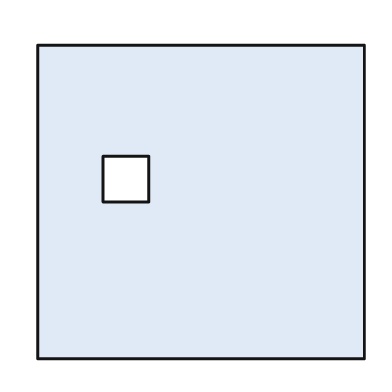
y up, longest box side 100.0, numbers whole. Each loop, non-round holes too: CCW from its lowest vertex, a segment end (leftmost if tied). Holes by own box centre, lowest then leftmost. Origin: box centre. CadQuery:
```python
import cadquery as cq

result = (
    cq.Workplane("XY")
    .moveTo(-50.0, -48.0)
    .lineTo(50.0, -48.0)
    .lineTo(50.0, 48.0)
    .lineTo(-50.0, 48.0)
    .close()
    .moveTo(-30.0, 0.0)
    .lineTo(-16.0, 0.0)
    .lineTo(-16.0, 14.0)
    .lineTo(-30.0, 14.0)
    .close()
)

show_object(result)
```